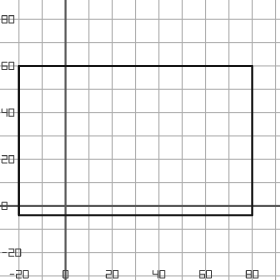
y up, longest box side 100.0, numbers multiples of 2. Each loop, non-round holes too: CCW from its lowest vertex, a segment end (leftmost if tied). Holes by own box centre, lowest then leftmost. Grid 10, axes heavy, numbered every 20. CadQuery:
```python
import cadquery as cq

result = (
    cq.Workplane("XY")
    .moveTo(-20.0, -4.0)
    .lineTo(80.0, -4.0)
    .lineTo(80.0, 60.0)
    .lineTo(-20.0, 60.0)
    .close()
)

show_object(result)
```